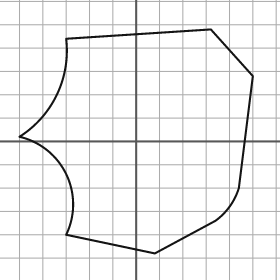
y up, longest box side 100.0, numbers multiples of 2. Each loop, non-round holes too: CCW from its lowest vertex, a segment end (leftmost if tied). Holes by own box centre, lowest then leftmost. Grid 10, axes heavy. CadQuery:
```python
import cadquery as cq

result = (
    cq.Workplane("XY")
    .moveTo(8.0, -48.0)
    .lineTo(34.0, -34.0)
    .threePointArc((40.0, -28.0), (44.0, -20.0))
    .lineTo(50.0, 28.0)
    .lineTo(32.0, 48.0)
    .lineTo(-30.0, 44.0)
    .threePointArc((-34.0, 20.0), (-50.0, 2.0))
    .threePointArc((-30.0, -14.0), (-30.0, -40.0))
    .close()
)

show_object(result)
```